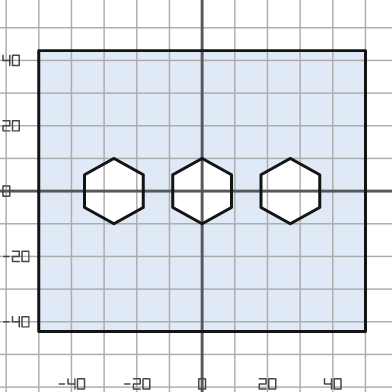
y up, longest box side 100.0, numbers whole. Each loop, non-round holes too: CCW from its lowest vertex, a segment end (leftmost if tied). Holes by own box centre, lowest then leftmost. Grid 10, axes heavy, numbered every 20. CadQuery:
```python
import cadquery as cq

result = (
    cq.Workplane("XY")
    .moveTo(-50.0, -43.0)
    .lineTo(50.0, -43.0)
    .lineTo(50.0, 43.0)
    .lineTo(-50.0, 43.0)
    .close()
    .moveTo(-27.0, -10.0)
    .lineTo(-18.0, -5.0)
    .lineTo(-18.0, 5.0)
    .lineTo(-27.0, 10.0)
    .lineTo(-36.0, 5.0)
    .lineTo(-36.0, -5.0)
    .close()
    .moveTo(0.0, -10.0)
    .lineTo(9.0, -5.0)
    .lineTo(9.0, 5.0)
    .lineTo(0.0, 10.0)
    .lineTo(-9.0, 5.0)
    .lineTo(-9.0, -5.0)
    .close()
    .moveTo(27.0, -10.0)
    .lineTo(36.0, -5.0)
    .lineTo(36.0, 5.0)
    .lineTo(27.0, 10.0)
    .lineTo(18.0, 5.0)
    .lineTo(18.0, -5.0)
    .close()
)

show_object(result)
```